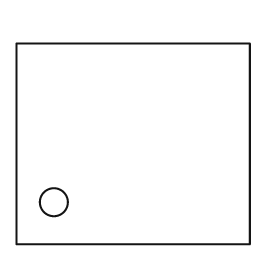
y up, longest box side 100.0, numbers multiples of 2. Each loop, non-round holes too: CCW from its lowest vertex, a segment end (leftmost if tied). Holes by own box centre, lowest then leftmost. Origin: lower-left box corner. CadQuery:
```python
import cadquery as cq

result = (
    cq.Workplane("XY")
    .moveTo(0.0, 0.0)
    .lineTo(100.0, 0.0)
    .lineTo(100.0, 86.0)
    .lineTo(0.0, 86.0)
    .close()
    .moveTo(16.0, 18.0)
    .circle(6.0)
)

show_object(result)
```